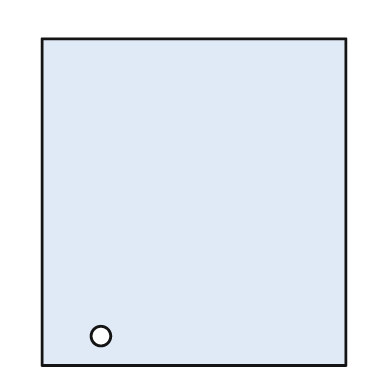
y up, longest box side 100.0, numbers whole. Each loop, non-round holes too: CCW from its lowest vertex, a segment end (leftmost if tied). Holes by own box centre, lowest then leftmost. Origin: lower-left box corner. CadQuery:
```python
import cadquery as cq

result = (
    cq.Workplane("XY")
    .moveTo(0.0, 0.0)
    .lineTo(93.0, 0.0)
    .lineTo(93.0, 100.0)
    .lineTo(0.0, 100.0)
    .close()
    .moveTo(18.0, 9.0)
    .circle(3.0)
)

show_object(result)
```